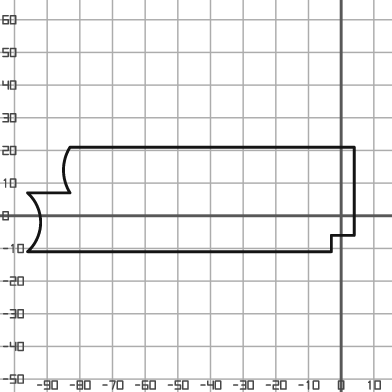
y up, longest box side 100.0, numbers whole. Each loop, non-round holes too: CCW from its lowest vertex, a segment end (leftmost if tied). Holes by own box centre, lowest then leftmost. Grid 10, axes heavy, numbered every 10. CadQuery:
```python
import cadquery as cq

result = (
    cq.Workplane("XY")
    .moveTo(-96.0, -11.0)
    .lineTo(-3.0, -11.0)
    .lineTo(-3.0, -6.0)
    .lineTo(4.0, -6.0)
    .lineTo(4.0, 21.0)
    .lineTo(-83.0, 21.0)
    .threePointArc((-85.0, 14.0), (-83.0, 7.0))
    .lineTo(-96.0, 7.0)
    .threePointArc((-92.0, -2.0), (-96.0, -11.0))
    .close()
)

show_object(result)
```